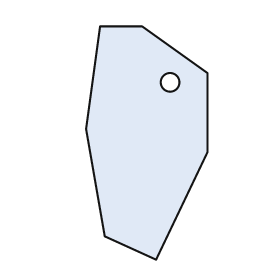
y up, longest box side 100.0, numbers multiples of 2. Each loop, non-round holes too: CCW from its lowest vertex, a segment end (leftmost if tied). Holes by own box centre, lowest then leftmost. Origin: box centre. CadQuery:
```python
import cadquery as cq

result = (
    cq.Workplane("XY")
    .moveTo(4.0, -50.0)
    .lineTo(26.0, -4.0)
    .lineTo(26.0, 30.0)
    .lineTo(-2.0, 50.0)
    .lineTo(-20.0, 50.0)
    .lineTo(-26.0, 6.0)
    .lineTo(-18.0, -40.0)
    .close()
    .moveTo(10.0, 26.0)
    .circle(4.0)
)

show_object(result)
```